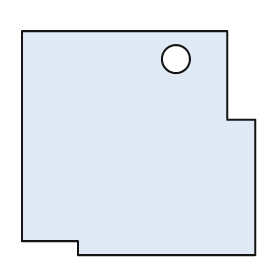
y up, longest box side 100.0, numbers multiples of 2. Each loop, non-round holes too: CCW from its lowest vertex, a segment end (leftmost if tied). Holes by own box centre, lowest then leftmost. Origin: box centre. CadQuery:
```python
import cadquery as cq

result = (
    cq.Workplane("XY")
    .moveTo(-26.0, -48.0)
    .lineTo(50.0, -48.0)
    .lineTo(50.0, 10.0)
    .lineTo(38.0, 10.0)
    .lineTo(38.0, 48.0)
    .lineTo(-50.0, 48.0)
    .lineTo(-50.0, -42.0)
    .lineTo(-26.0, -42.0)
    .close()
    .moveTo(16.0, 36.0)
    .circle(6.0)
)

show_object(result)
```